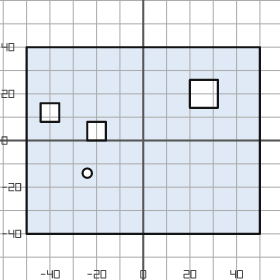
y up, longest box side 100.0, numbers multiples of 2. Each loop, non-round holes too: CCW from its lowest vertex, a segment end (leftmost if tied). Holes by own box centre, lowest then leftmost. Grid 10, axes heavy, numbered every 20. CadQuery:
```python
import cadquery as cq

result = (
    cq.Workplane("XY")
    .moveTo(-50.0, -40.0)
    .lineTo(50.0, -40.0)
    .lineTo(50.0, 40.0)
    .lineTo(-50.0, 40.0)
    .close()
    .moveTo(-24.0, -14.0)
    .circle(2.0)
    .moveTo(-24.0, 0.0)
    .lineTo(-16.0, 0.0)
    .lineTo(-16.0, 8.0)
    .lineTo(-24.0, 8.0)
    .close()
    .moveTo(-44.0, 8.0)
    .lineTo(-36.0, 8.0)
    .lineTo(-36.0, 16.0)
    .lineTo(-44.0, 16.0)
    .close()
    .moveTo(20.0, 14.0)
    .lineTo(32.0, 14.0)
    .lineTo(32.0, 26.0)
    .lineTo(20.0, 26.0)
    .close()
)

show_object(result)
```